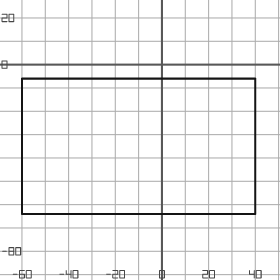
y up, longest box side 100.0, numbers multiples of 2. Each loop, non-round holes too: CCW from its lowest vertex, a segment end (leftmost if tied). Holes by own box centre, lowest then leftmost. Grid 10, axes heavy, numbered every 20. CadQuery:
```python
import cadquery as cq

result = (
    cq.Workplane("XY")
    .moveTo(-60.0, -64.0)
    .lineTo(40.0, -64.0)
    .lineTo(40.0, -6.0)
    .lineTo(-60.0, -6.0)
    .close()
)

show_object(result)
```